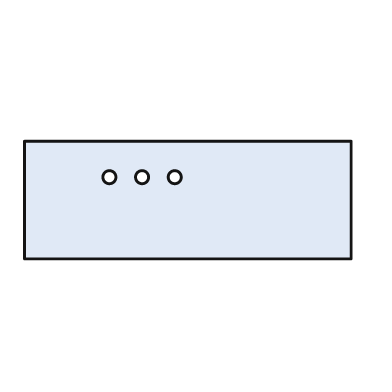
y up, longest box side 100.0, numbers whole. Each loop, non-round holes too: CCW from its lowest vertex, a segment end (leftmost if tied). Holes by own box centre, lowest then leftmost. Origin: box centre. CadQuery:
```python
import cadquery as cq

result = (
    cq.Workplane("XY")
    .moveTo(-50.0, -18.0)
    .lineTo(50.0, -18.0)
    .lineTo(50.0, 18.0)
    .lineTo(-50.0, 18.0)
    .close()
    .moveTo(-24.0, 7.0)
    .circle(2.0)
    .moveTo(-14.0, 7.0)
    .circle(2.0)
    .moveTo(-4.0, 7.0)
    .circle(2.0)
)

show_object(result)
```